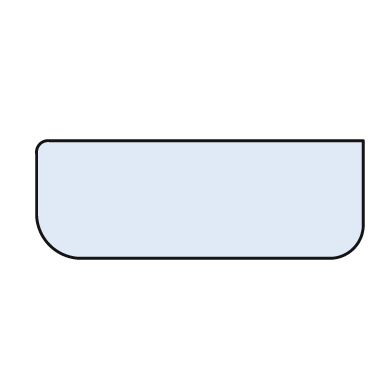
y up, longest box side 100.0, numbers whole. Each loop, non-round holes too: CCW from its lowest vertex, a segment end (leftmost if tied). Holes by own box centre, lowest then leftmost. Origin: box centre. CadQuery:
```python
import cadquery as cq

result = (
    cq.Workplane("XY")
    .moveTo(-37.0, -18.0)
    .lineTo(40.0, -18.0)
    .threePointArc((47.0, -15.0), (50.0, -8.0))
    .lineTo(50.0, 18.0)
    .lineTo(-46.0, 18.0)
    .threePointArc((-49.0, 17.0), (-50.0, 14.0))
    .lineTo(-50.0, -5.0)
    .threePointArc((-46.0, -14.0), (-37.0, -18.0))
    .close()
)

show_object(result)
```